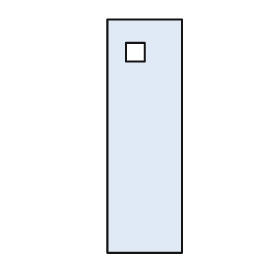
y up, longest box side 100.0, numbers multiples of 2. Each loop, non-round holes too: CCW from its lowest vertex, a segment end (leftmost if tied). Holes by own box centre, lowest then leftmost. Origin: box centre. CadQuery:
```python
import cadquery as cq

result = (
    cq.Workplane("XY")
    .moveTo(-16.0, -50.0)
    .lineTo(16.0, -50.0)
    .lineTo(16.0, 50.0)
    .lineTo(-16.0, 50.0)
    .close()
    .moveTo(-8.0, 32.0)
    .lineTo(0.0, 32.0)
    .lineTo(0.0, 40.0)
    .lineTo(-8.0, 40.0)
    .close()
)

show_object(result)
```